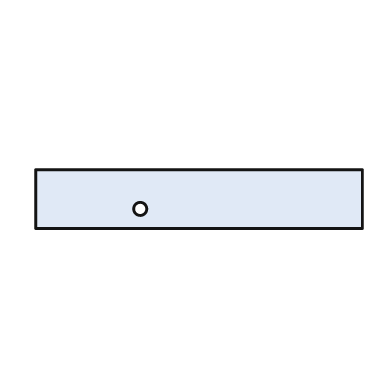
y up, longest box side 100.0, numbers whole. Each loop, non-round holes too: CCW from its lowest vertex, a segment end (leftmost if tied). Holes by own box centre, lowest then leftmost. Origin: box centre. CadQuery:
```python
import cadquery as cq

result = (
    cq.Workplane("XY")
    .moveTo(-50.0, -9.0)
    .lineTo(50.0, -9.0)
    .lineTo(50.0, 9.0)
    .lineTo(-50.0, 9.0)
    .close()
    .moveTo(-18.0, -3.0)
    .circle(2.0)
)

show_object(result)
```